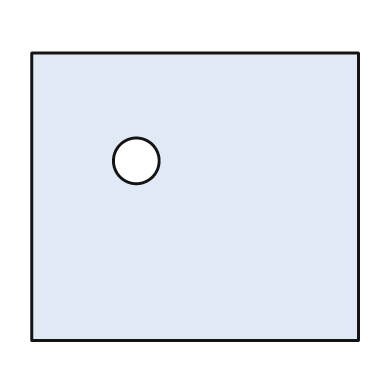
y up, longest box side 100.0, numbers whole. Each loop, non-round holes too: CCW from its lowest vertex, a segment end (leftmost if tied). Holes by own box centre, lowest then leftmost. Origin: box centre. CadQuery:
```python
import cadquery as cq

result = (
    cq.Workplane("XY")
    .moveTo(-50.0, -44.0)
    .lineTo(50.0, -44.0)
    .lineTo(50.0, 44.0)
    .lineTo(-50.0, 44.0)
    .close()
    .moveTo(-18.0, 11.0)
    .circle(7.0)
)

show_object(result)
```